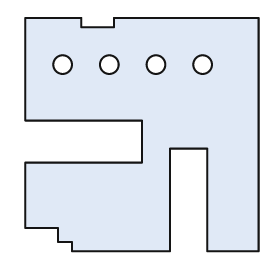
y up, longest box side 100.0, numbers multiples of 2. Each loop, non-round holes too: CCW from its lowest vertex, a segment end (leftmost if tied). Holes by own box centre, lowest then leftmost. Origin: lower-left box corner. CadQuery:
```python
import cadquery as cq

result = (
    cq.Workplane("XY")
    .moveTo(20.0, 0.0)
    .lineTo(62.0, 0.0)
    .lineTo(62.0, 44.0)
    .lineTo(78.0, 44.0)
    .lineTo(78.0, 0.0)
    .lineTo(100.0, 0.0)
    .lineTo(100.0, 100.0)
    .lineTo(38.0, 100.0)
    .lineTo(38.0, 96.0)
    .lineTo(24.0, 96.0)
    .lineTo(24.0, 100.0)
    .lineTo(0.0, 100.0)
    .lineTo(0.0, 56.0)
    .lineTo(50.0, 56.0)
    .lineTo(50.0, 38.0)
    .lineTo(0.0, 38.0)
    .lineTo(0.0, 10.0)
    .lineTo(14.0, 10.0)
    .lineTo(14.0, 4.0)
    .lineTo(20.0, 4.0)
    .close()
    .moveTo(16.0, 80.0)
    .circle(4.0)
    .moveTo(36.0, 80.0)
    .circle(4.0)
    .moveTo(56.0, 80.0)
    .circle(4.0)
    .moveTo(76.0, 80.0)
    .circle(4.0)
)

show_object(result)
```